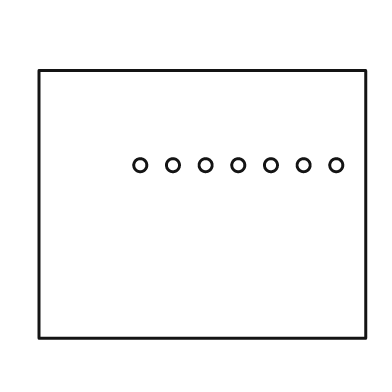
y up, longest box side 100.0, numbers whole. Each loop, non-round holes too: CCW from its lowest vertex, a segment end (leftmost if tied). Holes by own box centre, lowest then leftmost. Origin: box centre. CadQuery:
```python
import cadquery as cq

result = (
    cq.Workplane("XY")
    .moveTo(-50.0, -41.0)
    .lineTo(50.0, -41.0)
    .lineTo(50.0, 41.0)
    .lineTo(-50.0, 41.0)
    .close()
    .moveTo(-19.0, 12.0)
    .circle(2.0)
    .moveTo(-9.0, 12.0)
    .circle(2.0)
    .moveTo(1.0, 12.0)
    .circle(2.0)
    .moveTo(11.0, 12.0)
    .circle(2.0)
    .moveTo(21.0, 12.0)
    .circle(2.0)
    .moveTo(31.0, 12.0)
    .circle(2.0)
    .moveTo(41.0, 12.0)
    .circle(2.0)
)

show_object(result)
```